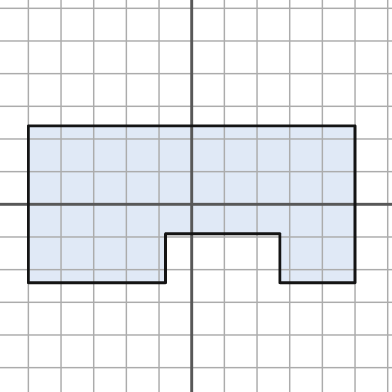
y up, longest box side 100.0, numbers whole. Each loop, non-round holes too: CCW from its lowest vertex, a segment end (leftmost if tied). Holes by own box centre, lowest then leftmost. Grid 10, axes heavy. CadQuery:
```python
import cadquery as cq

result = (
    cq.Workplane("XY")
    .moveTo(-50.0, -24.0)
    .lineTo(-8.0, -24.0)
    .lineTo(-8.0, -9.0)
    .lineTo(27.0, -9.0)
    .lineTo(27.0, -24.0)
    .lineTo(50.0, -24.0)
    .lineTo(50.0, 24.0)
    .lineTo(-50.0, 24.0)
    .close()
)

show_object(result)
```